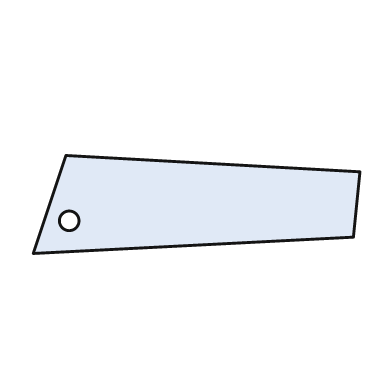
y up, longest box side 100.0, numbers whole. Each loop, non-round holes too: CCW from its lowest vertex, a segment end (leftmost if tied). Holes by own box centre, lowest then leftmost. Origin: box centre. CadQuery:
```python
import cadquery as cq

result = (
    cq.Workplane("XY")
    .moveTo(-50.0, -15.0)
    .lineTo(48.0, -10.0)
    .lineTo(50.0, 10.0)
    .lineTo(-40.0, 15.0)
    .close()
    .moveTo(-39.0, -5.0)
    .circle(3.0)
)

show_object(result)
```